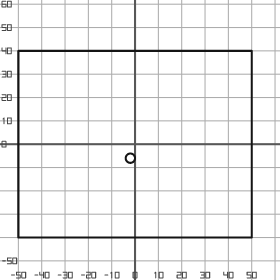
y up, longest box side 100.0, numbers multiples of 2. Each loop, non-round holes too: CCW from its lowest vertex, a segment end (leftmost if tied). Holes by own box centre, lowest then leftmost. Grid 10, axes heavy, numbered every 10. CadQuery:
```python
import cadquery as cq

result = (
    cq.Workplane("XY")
    .moveTo(-50.0, -40.0)
    .lineTo(50.0, -40.0)
    .lineTo(50.0, 40.0)
    .lineTo(-50.0, 40.0)
    .close()
    .moveTo(-2.0, -6.0)
    .circle(2.0)
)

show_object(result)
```